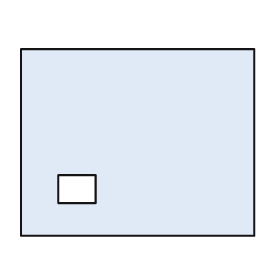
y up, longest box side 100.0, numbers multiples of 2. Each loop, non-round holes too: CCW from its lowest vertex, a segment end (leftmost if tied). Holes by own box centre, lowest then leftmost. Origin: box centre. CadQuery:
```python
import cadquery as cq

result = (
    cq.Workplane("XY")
    .moveTo(-50.0, -40.0)
    .lineTo(50.0, -40.0)
    .lineTo(50.0, 40.0)
    .lineTo(-50.0, 40.0)
    .close()
    .moveTo(-34.0, -26.0)
    .lineTo(-18.0, -26.0)
    .lineTo(-18.0, -14.0)
    .lineTo(-34.0, -14.0)
    .close()
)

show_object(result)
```